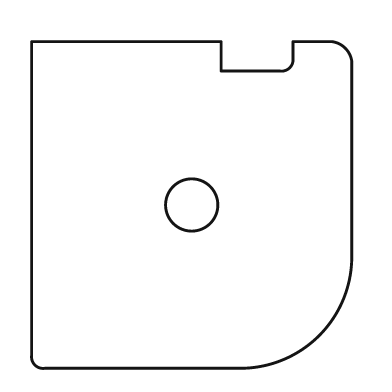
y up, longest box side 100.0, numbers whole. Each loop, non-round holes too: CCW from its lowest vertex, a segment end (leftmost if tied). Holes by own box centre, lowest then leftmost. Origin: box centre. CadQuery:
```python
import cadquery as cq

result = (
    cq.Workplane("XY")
    .moveTo(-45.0, -50.0)
    .lineTo(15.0, -50.0)
    .threePointArc((39.0, -40.0), (49.0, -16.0))
    .lineTo(49.0, 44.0)
    .threePointArc((47.0, 48.0), (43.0, 50.0))
    .lineTo(31.0, 50.0)
    .lineTo(31.0, 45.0)
    .threePointArc((30.0, 42.0), (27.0, 41.0))
    .lineTo(9.0, 41.0)
    .lineTo(9.0, 50.0)
    .lineTo(-49.0, 50.0)
    .lineTo(-49.0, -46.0)
    .threePointArc((-48.0, -49.0), (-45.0, -50.0))
    .close()
    .moveTo(0.0, 0.0)
    .circle(8.0)
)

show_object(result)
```